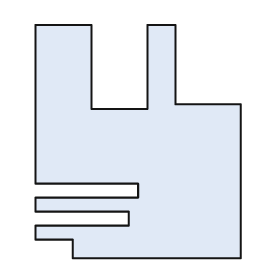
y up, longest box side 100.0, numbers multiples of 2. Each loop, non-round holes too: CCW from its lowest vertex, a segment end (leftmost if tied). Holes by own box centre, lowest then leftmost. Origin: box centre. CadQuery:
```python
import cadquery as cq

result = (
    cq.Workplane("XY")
    .moveTo(-28.0, -50.0)
    .lineTo(44.0, -50.0)
    .lineTo(44.0, 16.0)
    .lineTo(16.0, 16.0)
    .lineTo(16.0, 50.0)
    .lineTo(4.0, 50.0)
    .lineTo(4.0, 14.0)
    .lineTo(-20.0, 14.0)
    .lineTo(-20.0, 50.0)
    .lineTo(-44.0, 50.0)
    .lineTo(-44.0, -18.0)
    .lineTo(0.0, -18.0)
    .lineTo(0.0, -24.0)
    .lineTo(-44.0, -24.0)
    .lineTo(-44.0, -30.0)
    .lineTo(-4.0, -30.0)
    .lineTo(-4.0, -36.0)
    .lineTo(-44.0, -36.0)
    .lineTo(-44.0, -42.0)
    .lineTo(-28.0, -42.0)
    .close()
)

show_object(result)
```